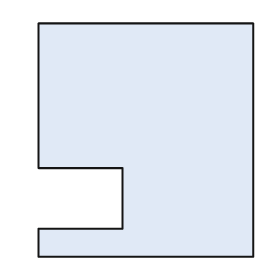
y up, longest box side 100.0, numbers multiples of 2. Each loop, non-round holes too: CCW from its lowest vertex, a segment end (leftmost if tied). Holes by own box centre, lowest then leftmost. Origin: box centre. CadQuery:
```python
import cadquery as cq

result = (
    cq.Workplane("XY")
    .moveTo(-46.0, -50.0)
    .lineTo(46.0, -50.0)
    .lineTo(46.0, 50.0)
    .lineTo(-46.0, 50.0)
    .lineTo(-46.0, -12.0)
    .lineTo(-10.0, -12.0)
    .lineTo(-10.0, -38.0)
    .lineTo(-46.0, -38.0)
    .close()
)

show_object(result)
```